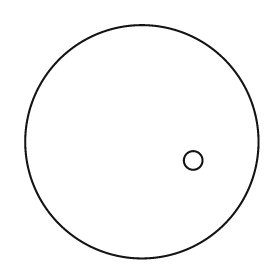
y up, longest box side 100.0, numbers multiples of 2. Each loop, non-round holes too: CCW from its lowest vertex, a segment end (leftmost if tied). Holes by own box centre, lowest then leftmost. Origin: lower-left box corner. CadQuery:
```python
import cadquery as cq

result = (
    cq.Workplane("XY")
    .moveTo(50.0, 50.0)
    .circle(50.0)
    .moveTo(72.0, 42.0)
    .circle(4.0)
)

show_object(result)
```